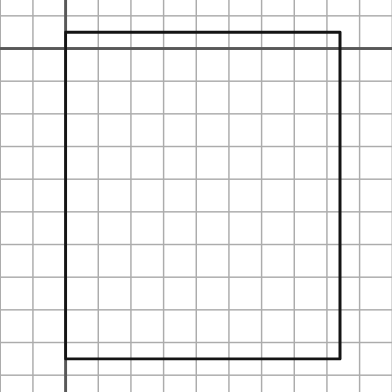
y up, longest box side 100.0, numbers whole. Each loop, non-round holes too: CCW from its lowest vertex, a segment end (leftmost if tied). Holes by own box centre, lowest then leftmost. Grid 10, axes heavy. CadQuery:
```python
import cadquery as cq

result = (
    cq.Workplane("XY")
    .moveTo(0.0, -95.0)
    .lineTo(84.0, -95.0)
    .lineTo(84.0, 5.0)
    .lineTo(0.0, 5.0)
    .close()
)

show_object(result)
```